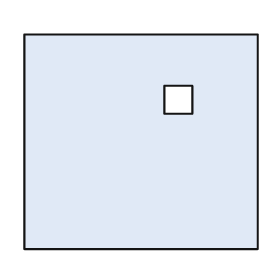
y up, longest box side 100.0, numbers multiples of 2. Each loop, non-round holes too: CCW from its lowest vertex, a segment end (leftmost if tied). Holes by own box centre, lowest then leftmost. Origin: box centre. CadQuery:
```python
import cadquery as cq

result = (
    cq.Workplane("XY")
    .moveTo(-50.0, -46.0)
    .lineTo(50.0, -46.0)
    .lineTo(50.0, 46.0)
    .lineTo(-50.0, 46.0)
    .close()
    .moveTo(10.0, 12.0)
    .lineTo(22.0, 12.0)
    .lineTo(22.0, 24.0)
    .lineTo(10.0, 24.0)
    .close()
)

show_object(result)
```